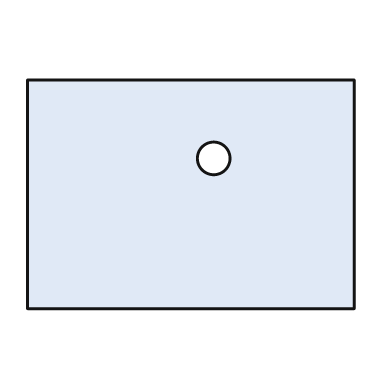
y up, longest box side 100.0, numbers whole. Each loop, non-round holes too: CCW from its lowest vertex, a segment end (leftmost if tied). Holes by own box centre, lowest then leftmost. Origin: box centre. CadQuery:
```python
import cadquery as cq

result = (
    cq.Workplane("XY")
    .moveTo(-50.0, -35.0)
    .lineTo(50.0, -35.0)
    .lineTo(50.0, 35.0)
    .lineTo(-50.0, 35.0)
    .close()
    .moveTo(7.0, 11.0)
    .circle(5.0)
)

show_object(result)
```